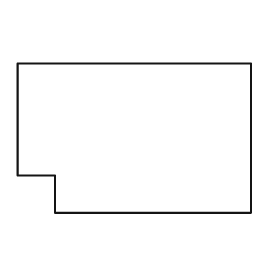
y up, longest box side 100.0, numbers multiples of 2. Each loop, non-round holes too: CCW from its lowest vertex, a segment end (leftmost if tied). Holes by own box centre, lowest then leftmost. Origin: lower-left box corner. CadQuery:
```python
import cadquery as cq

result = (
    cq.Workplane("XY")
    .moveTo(16.0, 0.0)
    .lineTo(100.0, 0.0)
    .lineTo(100.0, 64.0)
    .lineTo(0.0, 64.0)
    .lineTo(0.0, 16.0)
    .lineTo(16.0, 16.0)
    .close()
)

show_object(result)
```